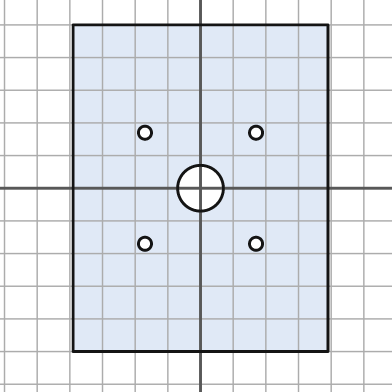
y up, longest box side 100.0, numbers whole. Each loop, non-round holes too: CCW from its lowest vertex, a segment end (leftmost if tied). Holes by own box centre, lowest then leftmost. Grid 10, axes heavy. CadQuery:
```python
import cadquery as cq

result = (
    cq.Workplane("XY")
    .moveTo(-39.0, -50.0)
    .lineTo(39.0, -50.0)
    .lineTo(39.0, 50.0)
    .lineTo(-39.0, 50.0)
    .close()
    .moveTo(-17.0, -17.0)
    .circle(2.0)
    .moveTo(17.0, -17.0)
    .circle(2.0)
    .moveTo(0.0, 0.0)
    .circle(7.0)
    .moveTo(-17.0, 17.0)
    .circle(2.0)
    .moveTo(17.0, 17.0)
    .circle(2.0)
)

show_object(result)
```